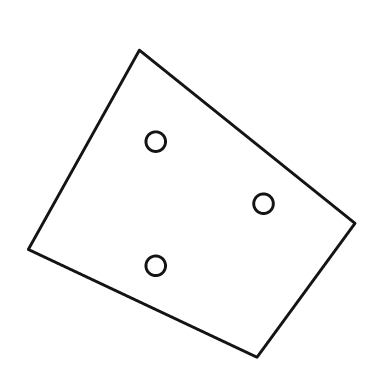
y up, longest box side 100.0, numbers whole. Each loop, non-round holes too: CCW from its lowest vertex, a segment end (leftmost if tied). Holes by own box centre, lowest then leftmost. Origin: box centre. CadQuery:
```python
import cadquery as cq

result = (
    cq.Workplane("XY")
    .moveTo(20.0, -47.0)
    .lineTo(50.0, -6.0)
    .lineTo(-16.0, 47.0)
    .lineTo(-50.0, -14.0)
    .close()
    .moveTo(-11.0, -19.0)
    .circle(3.0)
    .moveTo(22.0, 0.0)
    .circle(3.0)
    .moveTo(-11.0, 19.0)
    .circle(3.0)
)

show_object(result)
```